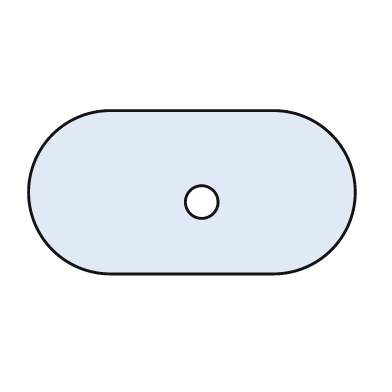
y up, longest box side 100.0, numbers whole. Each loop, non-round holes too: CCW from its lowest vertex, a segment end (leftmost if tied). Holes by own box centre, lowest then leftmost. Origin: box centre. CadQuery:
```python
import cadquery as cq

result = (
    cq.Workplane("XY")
    .moveTo(-25.0, -25.0)
    .lineTo(25.0, -25.0)
    .threePointArc((50.0, 0.0), (25.0, 25.0))
    .lineTo(-25.0, 25.0)
    .threePointArc((-50.0, 0.0), (-25.0, -25.0))
    .close()
    .moveTo(3.0, -3.0)
    .circle(5.0)
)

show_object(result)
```